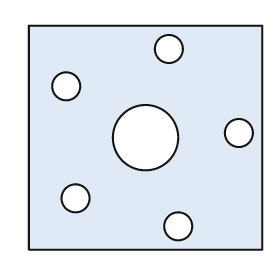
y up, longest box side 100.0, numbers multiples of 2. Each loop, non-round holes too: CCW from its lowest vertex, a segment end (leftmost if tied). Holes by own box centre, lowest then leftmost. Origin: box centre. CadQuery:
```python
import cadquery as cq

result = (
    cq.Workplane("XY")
    .moveTo(-50.0, -48.0)
    .lineTo(50.0, -48.0)
    .lineTo(50.0, 48.0)
    .lineTo(-50.0, 48.0)
    .close()
    .moveTo(14.0, -38.0)
    .circle(6.0)
    .moveTo(-30.0, -26.0)
    .circle(6.0)
    .moveTo(0.0, 0.0)
    .circle(14.0)
    .moveTo(40.0, 2.0)
    .circle(6.0)
    .moveTo(-34.0, 22.0)
    .circle(6.0)
    .moveTo(10.0, 38.0)
    .circle(6.0)
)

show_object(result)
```